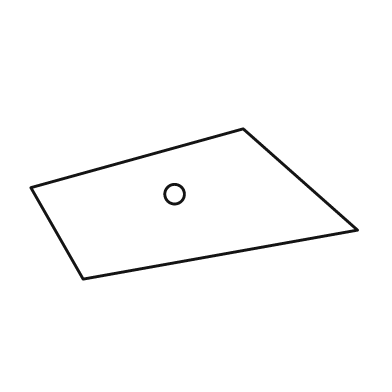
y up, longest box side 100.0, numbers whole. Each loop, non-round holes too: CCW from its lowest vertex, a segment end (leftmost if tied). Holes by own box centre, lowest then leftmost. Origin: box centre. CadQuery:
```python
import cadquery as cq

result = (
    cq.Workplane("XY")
    .moveTo(-34.0, -23.0)
    .lineTo(50.0, -8.0)
    .lineTo(15.0, 23.0)
    .lineTo(-50.0, 5.0)
    .close()
    .moveTo(-6.0, 3.0)
    .circle(3.0)
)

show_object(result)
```